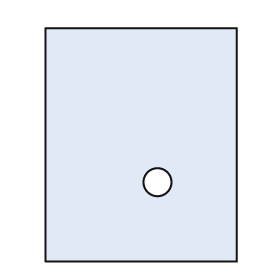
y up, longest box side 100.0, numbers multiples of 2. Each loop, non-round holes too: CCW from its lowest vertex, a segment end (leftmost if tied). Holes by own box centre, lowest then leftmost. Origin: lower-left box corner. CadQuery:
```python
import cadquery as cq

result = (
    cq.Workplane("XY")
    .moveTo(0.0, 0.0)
    .lineTo(82.0, 0.0)
    .lineTo(82.0, 100.0)
    .lineTo(0.0, 100.0)
    .close()
    .moveTo(48.0, 34.0)
    .circle(6.0)
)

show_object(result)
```